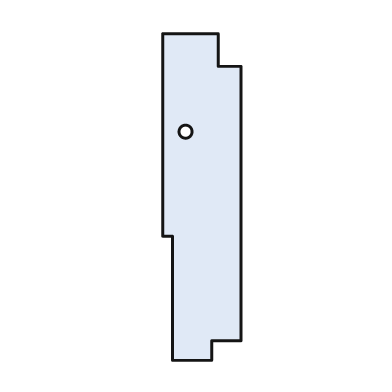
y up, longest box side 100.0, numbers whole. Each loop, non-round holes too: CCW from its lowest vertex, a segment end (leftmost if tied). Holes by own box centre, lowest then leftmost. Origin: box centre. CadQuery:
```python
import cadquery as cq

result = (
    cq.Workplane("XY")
    .moveTo(-9.0, -50.0)
    .lineTo(3.0, -50.0)
    .lineTo(3.0, -44.0)
    .lineTo(12.0, -44.0)
    .lineTo(12.0, 40.0)
    .lineTo(5.0, 40.0)
    .lineTo(5.0, 50.0)
    .lineTo(-12.0, 50.0)
    .lineTo(-12.0, -12.0)
    .lineTo(-9.0, -12.0)
    .close()
    .moveTo(-5.0, 20.0)
    .circle(2.0)
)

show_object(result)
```